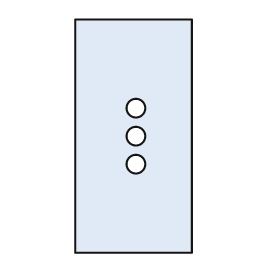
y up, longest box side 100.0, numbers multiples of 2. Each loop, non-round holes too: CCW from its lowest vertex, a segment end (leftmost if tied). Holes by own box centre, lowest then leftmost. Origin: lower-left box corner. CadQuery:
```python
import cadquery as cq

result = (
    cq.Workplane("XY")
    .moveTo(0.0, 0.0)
    .lineTo(50.0, 0.0)
    .lineTo(50.0, 100.0)
    .lineTo(0.0, 100.0)
    .close()
    .moveTo(26.0, 38.0)
    .circle(4.0)
    .moveTo(26.0, 50.0)
    .circle(4.0)
    .moveTo(26.0, 62.0)
    .circle(4.0)
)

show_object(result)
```